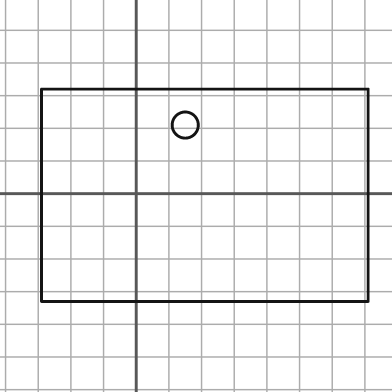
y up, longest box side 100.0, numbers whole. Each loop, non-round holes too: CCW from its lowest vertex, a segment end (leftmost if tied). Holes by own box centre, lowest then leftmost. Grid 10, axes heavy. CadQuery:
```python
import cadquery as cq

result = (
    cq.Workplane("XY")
    .moveTo(-29.0, -33.0)
    .lineTo(71.0, -33.0)
    .lineTo(71.0, 32.0)
    .lineTo(-29.0, 32.0)
    .close()
    .moveTo(15.0, 21.0)
    .circle(4.0)
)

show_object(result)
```